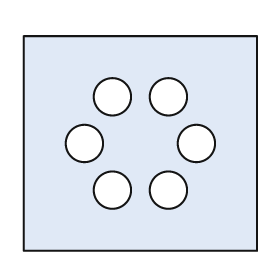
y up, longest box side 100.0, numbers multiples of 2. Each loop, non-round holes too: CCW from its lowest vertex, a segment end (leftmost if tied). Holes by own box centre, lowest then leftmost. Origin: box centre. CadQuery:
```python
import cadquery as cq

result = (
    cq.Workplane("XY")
    .moveTo(-50.0, -46.0)
    .lineTo(50.0, -46.0)
    .lineTo(50.0, 46.0)
    .lineTo(-50.0, 46.0)
    .close()
    .moveTo(-12.0, -20.0)
    .circle(8.0)
    .moveTo(12.0, -20.0)
    .circle(8.0)
    .moveTo(-24.0, 0.0)
    .circle(8.0)
    .moveTo(24.0, 0.0)
    .circle(8.0)
    .moveTo(-12.0, 20.0)
    .circle(8.0)
    .moveTo(12.0, 20.0)
    .circle(8.0)
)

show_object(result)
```